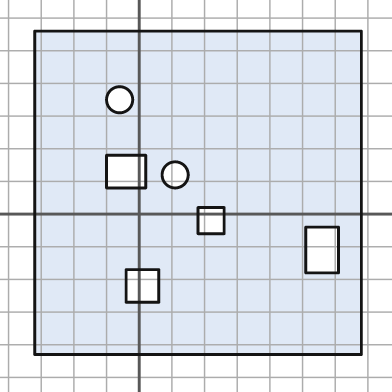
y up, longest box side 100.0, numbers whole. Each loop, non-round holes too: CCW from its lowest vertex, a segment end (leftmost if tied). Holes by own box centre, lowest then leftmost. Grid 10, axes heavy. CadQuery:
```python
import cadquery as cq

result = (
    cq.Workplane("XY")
    .moveTo(-32.0, -43.0)
    .lineTo(68.0, -43.0)
    .lineTo(68.0, 56.0)
    .lineTo(-32.0, 56.0)
    .close()
    .moveTo(-4.0, -27.0)
    .lineTo(6.0, -27.0)
    .lineTo(6.0, -17.0)
    .lineTo(-4.0, -17.0)
    .close()
    .moveTo(51.0, -18.0)
    .lineTo(61.0, -18.0)
    .lineTo(61.0, -4.0)
    .lineTo(51.0, -4.0)
    .close()
    .moveTo(18.0, -6.0)
    .lineTo(26.0, -6.0)
    .lineTo(26.0, 2.0)
    .lineTo(18.0, 2.0)
    .close()
    .moveTo(11.0, 12.0)
    .circle(4.0)
    .moveTo(-10.0, 8.0)
    .lineTo(2.0, 8.0)
    .lineTo(2.0, 18.0)
    .lineTo(-10.0, 18.0)
    .close()
    .moveTo(-6.0, 35.0)
    .circle(4.0)
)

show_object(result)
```